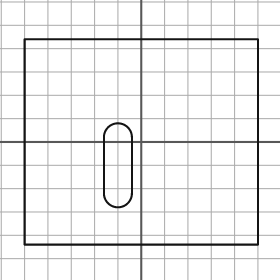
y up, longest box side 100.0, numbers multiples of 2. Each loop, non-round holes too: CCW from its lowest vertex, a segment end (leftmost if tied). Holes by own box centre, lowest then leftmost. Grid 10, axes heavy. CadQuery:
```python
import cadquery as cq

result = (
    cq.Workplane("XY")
    .moveTo(-50.0, -44.0)
    .lineTo(50.0, -44.0)
    .lineTo(50.0, 44.0)
    .lineTo(-50.0, 44.0)
    .close()
    .moveTo(-16.0, -22.0)
    .threePointArc((-10.0, -28.0), (-4.0, -22.0))
    .lineTo(-4.0, 2.0)
    .threePointArc((-10.0, 8.0), (-16.0, 2.0))
    .close()
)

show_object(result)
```